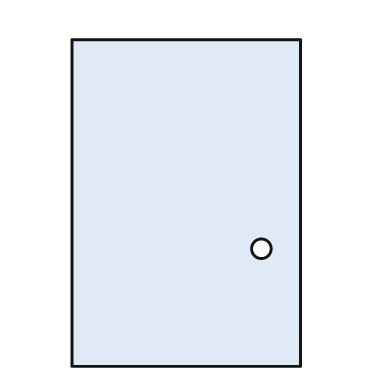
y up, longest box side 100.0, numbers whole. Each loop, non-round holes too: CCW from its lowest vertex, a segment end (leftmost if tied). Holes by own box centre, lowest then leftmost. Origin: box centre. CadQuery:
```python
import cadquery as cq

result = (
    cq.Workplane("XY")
    .moveTo(-35.0, -50.0)
    .lineTo(35.0, -50.0)
    .lineTo(35.0, 50.0)
    .lineTo(-35.0, 50.0)
    .close()
    .moveTo(23.0, -14.0)
    .circle(3.0)
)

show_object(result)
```